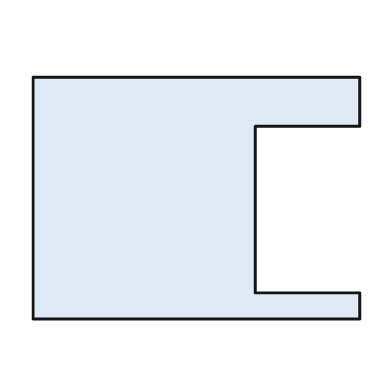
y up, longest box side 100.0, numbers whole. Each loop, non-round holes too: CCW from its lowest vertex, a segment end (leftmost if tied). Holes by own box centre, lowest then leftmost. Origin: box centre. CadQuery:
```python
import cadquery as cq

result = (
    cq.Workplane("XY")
    .moveTo(-50.0, -37.0)
    .lineTo(50.0, -37.0)
    .lineTo(50.0, -29.0)
    .lineTo(18.0, -29.0)
    .lineTo(18.0, 22.0)
    .lineTo(50.0, 22.0)
    .lineTo(50.0, 37.0)
    .lineTo(-50.0, 37.0)
    .close()
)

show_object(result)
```